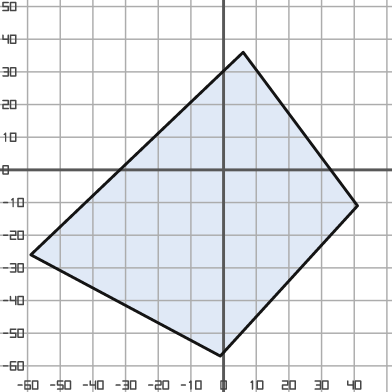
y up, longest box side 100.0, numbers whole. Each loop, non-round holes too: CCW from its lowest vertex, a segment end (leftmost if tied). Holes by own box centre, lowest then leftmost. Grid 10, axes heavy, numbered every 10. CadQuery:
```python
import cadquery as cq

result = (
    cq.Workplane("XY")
    .moveTo(-1.0, -57.0)
    .lineTo(41.0, -11.0)
    .lineTo(6.0, 36.0)
    .lineTo(-59.0, -26.0)
    .close()
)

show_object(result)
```